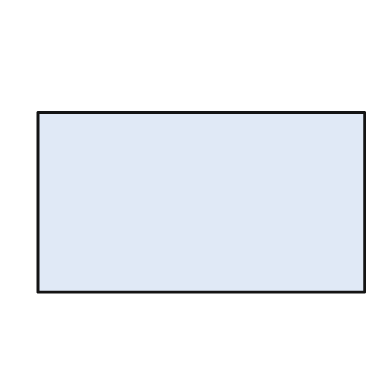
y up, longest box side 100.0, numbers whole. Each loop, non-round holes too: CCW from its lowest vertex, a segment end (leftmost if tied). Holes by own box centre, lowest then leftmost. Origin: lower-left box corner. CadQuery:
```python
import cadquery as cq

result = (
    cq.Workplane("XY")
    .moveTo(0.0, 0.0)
    .lineTo(100.0, 0.0)
    .lineTo(100.0, 55.0)
    .lineTo(0.0, 55.0)
    .close()
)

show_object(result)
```